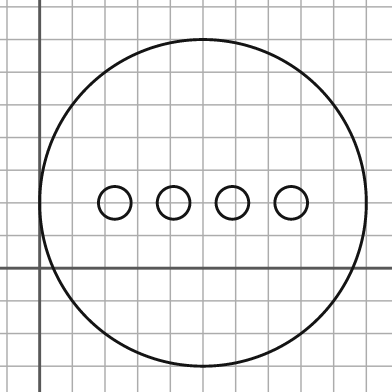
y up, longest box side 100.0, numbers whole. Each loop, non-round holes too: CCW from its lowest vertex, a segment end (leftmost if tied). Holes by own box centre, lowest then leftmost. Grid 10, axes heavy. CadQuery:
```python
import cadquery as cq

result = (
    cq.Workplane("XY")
    .moveTo(50.0, 20.0)
    .circle(50.0)
    .moveTo(23.0, 20.0)
    .circle(5.0)
    .moveTo(41.0, 20.0)
    .circle(5.0)
    .moveTo(59.0, 20.0)
    .circle(5.0)
    .moveTo(77.0, 20.0)
    .circle(5.0)
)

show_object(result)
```